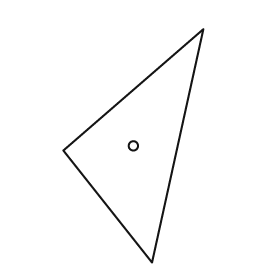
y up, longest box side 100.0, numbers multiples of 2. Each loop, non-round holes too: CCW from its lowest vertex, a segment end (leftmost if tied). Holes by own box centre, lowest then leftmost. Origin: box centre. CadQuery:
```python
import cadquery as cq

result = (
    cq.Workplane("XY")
    .moveTo(8.0, -50.0)
    .lineTo(30.0, 50.0)
    .lineTo(-30.0, -2.0)
    .close()
    .moveTo(0.0, 0.0)
    .circle(2.0)
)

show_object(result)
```